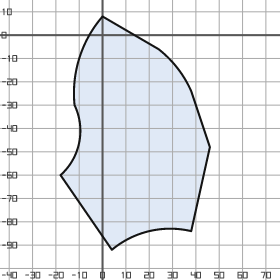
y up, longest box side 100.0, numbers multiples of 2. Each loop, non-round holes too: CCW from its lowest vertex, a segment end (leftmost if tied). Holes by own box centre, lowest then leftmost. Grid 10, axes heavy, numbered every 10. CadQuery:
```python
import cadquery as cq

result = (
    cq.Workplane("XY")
    .moveTo(4.0, -92.0)
    .threePointArc((20.0, -84.0), (38.0, -84.0))
    .lineTo(46.0, -48.0)
    .lineTo(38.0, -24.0)
    .threePointArc((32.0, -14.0), (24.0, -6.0))
    .lineTo(0.0, 8.0)
    .threePointArc((-10.0, -10.0), (-12.0, -30.0))
    .threePointArc((-10.0, -46.0), (-18.0, -60.0))
    .close()
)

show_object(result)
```